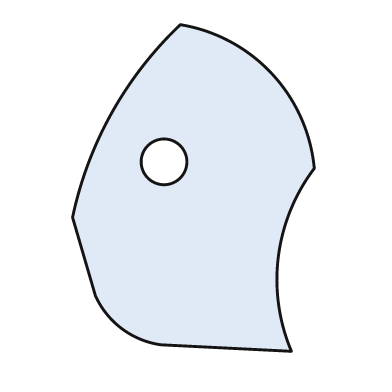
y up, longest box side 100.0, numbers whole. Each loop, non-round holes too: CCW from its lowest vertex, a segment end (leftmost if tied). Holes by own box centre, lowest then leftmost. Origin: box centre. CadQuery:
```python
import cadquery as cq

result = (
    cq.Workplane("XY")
    .moveTo(30.0, -50.0)
    .threePointArc((26.0, -21.0), (37.0, 6.0))
    .threePointArc((24.0, 35.0), (-4.0, 50.0))
    .threePointArc((-25.0, 23.0), (-37.0, -9.0))
    .lineTo(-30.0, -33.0)
    .threePointArc((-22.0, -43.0), (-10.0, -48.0))
    .close()
    .moveTo(-9.0, 8.0)
    .circle(7.0)
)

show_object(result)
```